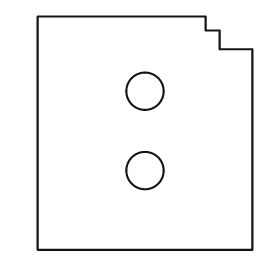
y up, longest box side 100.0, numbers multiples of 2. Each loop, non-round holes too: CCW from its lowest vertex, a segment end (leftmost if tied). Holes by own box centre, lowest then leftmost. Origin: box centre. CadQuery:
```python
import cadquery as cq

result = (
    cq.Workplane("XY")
    .moveTo(-46.0, -50.0)
    .lineTo(46.0, -50.0)
    .lineTo(46.0, 36.0)
    .lineTo(32.0, 36.0)
    .lineTo(32.0, 44.0)
    .lineTo(26.0, 44.0)
    .lineTo(26.0, 50.0)
    .lineTo(-46.0, 50.0)
    .close()
    .moveTo(0.0, -16.0)
    .circle(8.0)
    .moveTo(0.0, 18.0)
    .circle(8.0)
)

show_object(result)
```